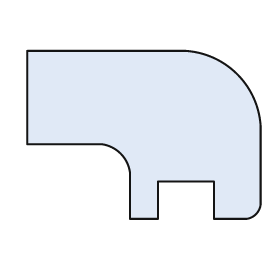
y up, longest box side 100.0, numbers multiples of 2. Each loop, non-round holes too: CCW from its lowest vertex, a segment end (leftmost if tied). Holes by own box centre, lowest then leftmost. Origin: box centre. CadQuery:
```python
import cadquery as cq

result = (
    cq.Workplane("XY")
    .moveTo(-6.0, -36.0)
    .lineTo(6.0, -36.0)
    .lineTo(6.0, -20.0)
    .lineTo(30.0, -20.0)
    .lineTo(30.0, -36.0)
    .lineTo(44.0, -36.0)
    .threePointArc((48.0, -34.0), (50.0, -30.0))
    .lineTo(50.0, 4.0)
    .threePointArc((40.0, 26.0), (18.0, 36.0))
    .lineTo(-50.0, 36.0)
    .lineTo(-50.0, -4.0)
    .lineTo(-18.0, -4.0)
    .threePointArc((-10.0, -8.0), (-6.0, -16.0))
    .close()
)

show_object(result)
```